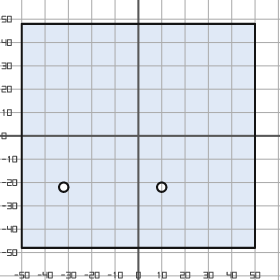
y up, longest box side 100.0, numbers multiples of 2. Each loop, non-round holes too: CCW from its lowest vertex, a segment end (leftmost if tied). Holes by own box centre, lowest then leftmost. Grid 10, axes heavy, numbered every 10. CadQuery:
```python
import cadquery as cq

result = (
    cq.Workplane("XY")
    .moveTo(-50.0, -48.0)
    .lineTo(50.0, -48.0)
    .lineTo(50.0, 48.0)
    .lineTo(-50.0, 48.0)
    .close()
    .moveTo(-32.0, -22.0)
    .circle(2.0)
    .moveTo(10.0, -22.0)
    .circle(2.0)
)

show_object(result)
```